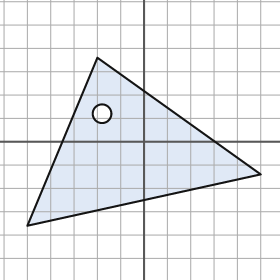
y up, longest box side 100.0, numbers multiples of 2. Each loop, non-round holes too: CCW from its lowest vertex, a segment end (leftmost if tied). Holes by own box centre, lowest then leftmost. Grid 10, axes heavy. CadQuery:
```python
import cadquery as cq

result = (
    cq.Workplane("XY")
    .moveTo(-50.0, -36.0)
    .lineTo(50.0, -14.0)
    .lineTo(-20.0, 36.0)
    .close()
    .moveTo(-18.0, 12.0)
    .circle(4.0)
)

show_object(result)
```